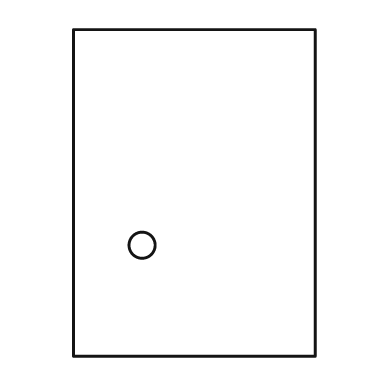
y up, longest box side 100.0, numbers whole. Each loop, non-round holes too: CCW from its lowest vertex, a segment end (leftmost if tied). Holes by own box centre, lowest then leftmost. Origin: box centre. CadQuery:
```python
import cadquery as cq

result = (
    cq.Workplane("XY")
    .moveTo(-37.0, -50.0)
    .lineTo(37.0, -50.0)
    .lineTo(37.0, 50.0)
    .lineTo(-37.0, 50.0)
    .close()
    .moveTo(-16.0, -16.0)
    .circle(4.0)
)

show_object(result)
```